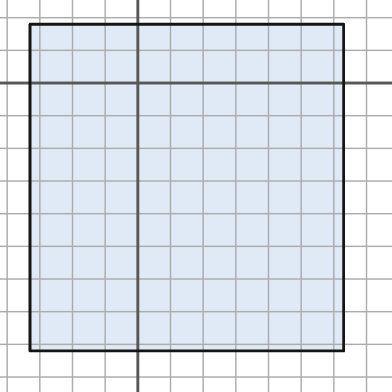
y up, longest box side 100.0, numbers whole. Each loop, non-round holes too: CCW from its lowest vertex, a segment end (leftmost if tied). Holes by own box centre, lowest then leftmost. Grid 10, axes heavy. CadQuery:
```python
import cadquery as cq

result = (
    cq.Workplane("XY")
    .moveTo(-33.0, -82.0)
    .lineTo(63.0, -82.0)
    .lineTo(63.0, 18.0)
    .lineTo(-33.0, 18.0)
    .close()
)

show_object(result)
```